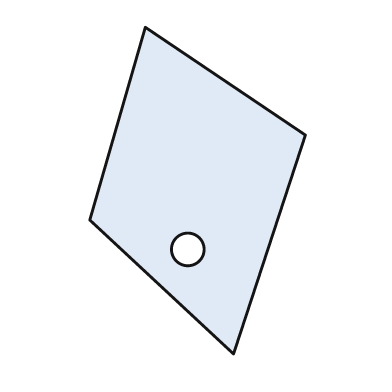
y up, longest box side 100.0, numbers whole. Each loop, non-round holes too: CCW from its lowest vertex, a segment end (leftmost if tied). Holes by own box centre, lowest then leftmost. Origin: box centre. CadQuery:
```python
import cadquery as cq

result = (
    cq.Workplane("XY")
    .moveTo(11.0, -50.0)
    .lineTo(33.0, 17.0)
    .lineTo(-16.0, 50.0)
    .lineTo(-33.0, -9.0)
    .close()
    .moveTo(-3.0, -18.0)
    .circle(5.0)
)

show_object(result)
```